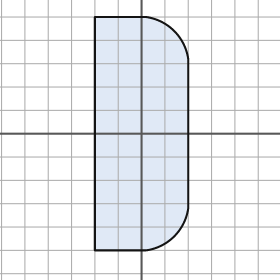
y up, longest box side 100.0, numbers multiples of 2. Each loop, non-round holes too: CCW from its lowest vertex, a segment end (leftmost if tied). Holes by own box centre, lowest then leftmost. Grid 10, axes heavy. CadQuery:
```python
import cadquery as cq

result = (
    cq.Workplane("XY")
    .moveTo(-20.0, -50.0)
    .lineTo(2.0, -50.0)
    .threePointArc((14.0, -44.0), (20.0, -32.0))
    .lineTo(20.0, 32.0)
    .threePointArc((14.0, 44.0), (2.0, 50.0))
    .lineTo(-20.0, 50.0)
    .close()
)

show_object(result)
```